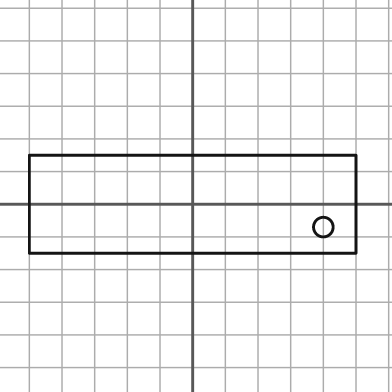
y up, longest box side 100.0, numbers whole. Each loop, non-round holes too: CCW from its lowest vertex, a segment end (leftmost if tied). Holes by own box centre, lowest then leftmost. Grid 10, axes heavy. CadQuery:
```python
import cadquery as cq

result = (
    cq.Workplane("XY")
    .moveTo(-50.0, -15.0)
    .lineTo(50.0, -15.0)
    .lineTo(50.0, 15.0)
    .lineTo(-50.0, 15.0)
    .close()
    .moveTo(40.0, -7.0)
    .circle(3.0)
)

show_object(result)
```